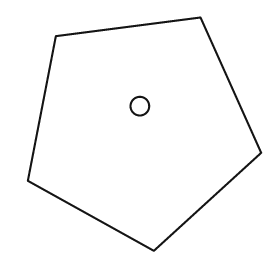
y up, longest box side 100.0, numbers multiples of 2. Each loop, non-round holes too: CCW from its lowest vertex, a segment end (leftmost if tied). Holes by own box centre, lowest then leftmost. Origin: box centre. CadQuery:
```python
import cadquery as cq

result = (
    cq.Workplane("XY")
    .moveTo(4.0, -50.0)
    .lineTo(50.0, -8.0)
    .lineTo(24.0, 50.0)
    .lineTo(-38.0, 42.0)
    .lineTo(-50.0, -20.0)
    .close()
    .moveTo(-2.0, 12.0)
    .circle(4.0)
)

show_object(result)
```